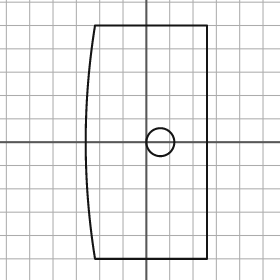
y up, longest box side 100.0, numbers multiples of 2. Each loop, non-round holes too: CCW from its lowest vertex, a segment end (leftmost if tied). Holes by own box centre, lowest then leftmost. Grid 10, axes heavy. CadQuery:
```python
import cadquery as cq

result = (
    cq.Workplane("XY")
    .moveTo(-22.0, -50.0)
    .lineTo(26.0, -50.0)
    .lineTo(26.0, 50.0)
    .lineTo(-22.0, 50.0)
    .threePointArc((-26.0, 0.0), (-22.0, -50.0))
    .close()
    .moveTo(6.0, 0.0)
    .circle(6.0)
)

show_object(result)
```